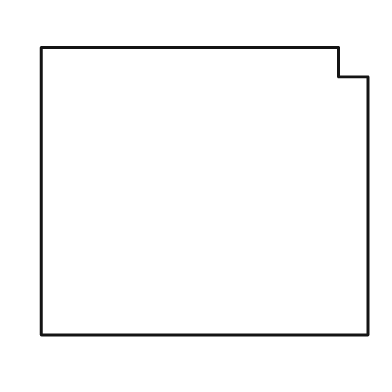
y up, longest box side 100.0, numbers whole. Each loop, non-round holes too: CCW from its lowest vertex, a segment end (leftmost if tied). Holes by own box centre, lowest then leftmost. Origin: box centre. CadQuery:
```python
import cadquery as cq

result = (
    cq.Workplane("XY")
    .moveTo(-50.0, -44.0)
    .lineTo(50.0, -44.0)
    .lineTo(50.0, 35.0)
    .lineTo(41.0, 35.0)
    .lineTo(41.0, 44.0)
    .lineTo(-50.0, 44.0)
    .close()
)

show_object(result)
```